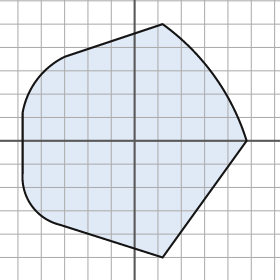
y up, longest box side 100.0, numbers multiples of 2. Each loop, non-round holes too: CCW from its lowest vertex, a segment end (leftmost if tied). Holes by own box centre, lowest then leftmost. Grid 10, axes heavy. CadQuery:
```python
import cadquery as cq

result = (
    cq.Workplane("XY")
    .moveTo(12.0, -50.0)
    .lineTo(48.0, 0.0)
    .threePointArc((34.0, 28.0), (12.0, 50.0))
    .lineTo(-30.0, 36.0)
    .threePointArc((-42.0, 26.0), (-48.0, 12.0))
    .lineTo(-48.0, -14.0)
    .threePointArc((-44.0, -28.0), (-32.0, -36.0))
    .close()
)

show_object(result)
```